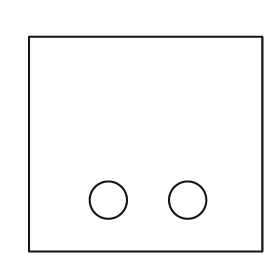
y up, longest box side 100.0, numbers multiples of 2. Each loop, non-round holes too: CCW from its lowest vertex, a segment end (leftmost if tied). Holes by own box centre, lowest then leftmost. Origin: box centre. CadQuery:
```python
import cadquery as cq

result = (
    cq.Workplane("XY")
    .moveTo(-50.0, -46.0)
    .lineTo(50.0, -46.0)
    .lineTo(50.0, 46.0)
    .lineTo(-50.0, 46.0)
    .close()
    .moveTo(-16.0, -24.0)
    .circle(8.0)
    .moveTo(18.0, -24.0)
    .circle(8.0)
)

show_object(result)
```